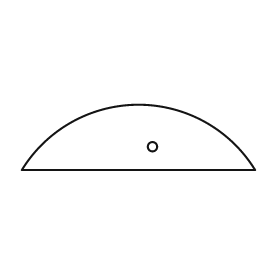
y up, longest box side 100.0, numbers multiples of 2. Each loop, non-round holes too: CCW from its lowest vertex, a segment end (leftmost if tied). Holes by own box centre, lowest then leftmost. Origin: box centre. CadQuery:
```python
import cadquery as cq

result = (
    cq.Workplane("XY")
    .moveTo(-50.0, -14.0)
    .lineTo(50.0, -14.0)
    .threePointArc((0.0, 14.0), (-50.0, -14.0))
    .close()
    .moveTo(6.0, -4.0)
    .circle(2.0)
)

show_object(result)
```